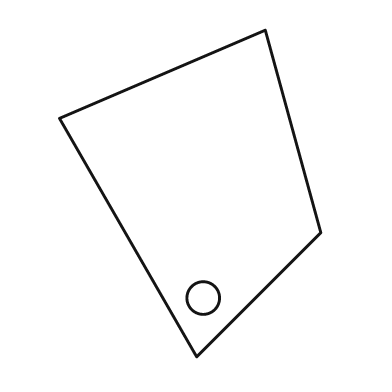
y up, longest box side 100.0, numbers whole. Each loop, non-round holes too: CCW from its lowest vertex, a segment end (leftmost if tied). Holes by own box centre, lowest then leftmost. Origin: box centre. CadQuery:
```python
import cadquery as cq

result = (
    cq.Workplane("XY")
    .moveTo(2.0, -50.0)
    .lineTo(40.0, -12.0)
    .lineTo(23.0, 50.0)
    .lineTo(-40.0, 23.0)
    .close()
    .moveTo(4.0, -32.0)
    .circle(5.0)
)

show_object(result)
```